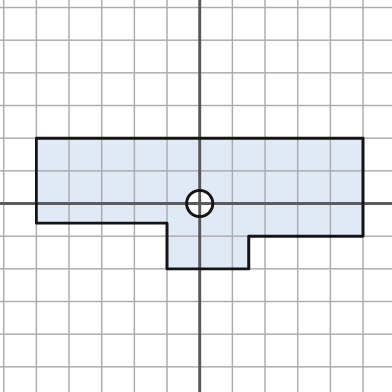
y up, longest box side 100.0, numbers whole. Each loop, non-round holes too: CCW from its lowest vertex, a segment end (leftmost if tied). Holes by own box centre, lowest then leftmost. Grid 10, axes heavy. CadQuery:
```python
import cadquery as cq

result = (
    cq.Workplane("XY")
    .moveTo(-10.0, -20.0)
    .lineTo(15.0, -20.0)
    .lineTo(15.0, -10.0)
    .lineTo(50.0, -10.0)
    .lineTo(50.0, 20.0)
    .lineTo(-50.0, 20.0)
    .lineTo(-50.0, -6.0)
    .lineTo(-10.0, -6.0)
    .close()
    .moveTo(0.0, 0.0)
    .circle(4.0)
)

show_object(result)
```